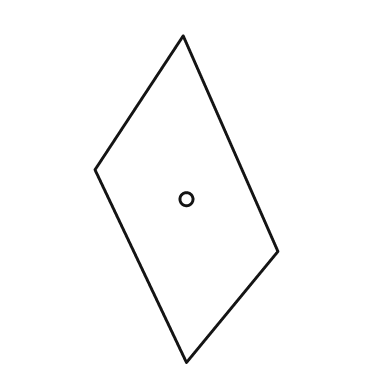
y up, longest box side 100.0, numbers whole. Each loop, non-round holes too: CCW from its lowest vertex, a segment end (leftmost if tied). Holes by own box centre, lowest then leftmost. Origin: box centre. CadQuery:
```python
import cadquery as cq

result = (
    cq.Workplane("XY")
    .moveTo(0.0, -50.0)
    .lineTo(28.0, -16.0)
    .lineTo(-1.0, 50.0)
    .lineTo(-28.0, 9.0)
    .close()
    .moveTo(0.0, 0.0)
    .circle(2.0)
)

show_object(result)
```